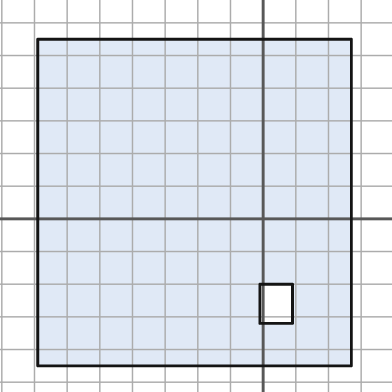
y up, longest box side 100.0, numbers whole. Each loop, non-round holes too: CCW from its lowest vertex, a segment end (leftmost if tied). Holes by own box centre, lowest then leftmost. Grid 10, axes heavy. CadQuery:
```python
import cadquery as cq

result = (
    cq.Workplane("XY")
    .moveTo(-69.0, -45.0)
    .lineTo(27.0, -45.0)
    .lineTo(27.0, 55.0)
    .lineTo(-69.0, 55.0)
    .close()
    .moveTo(-1.0, -32.0)
    .lineTo(9.0, -32.0)
    .lineTo(9.0, -20.0)
    .lineTo(-1.0, -20.0)
    .close()
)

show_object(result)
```